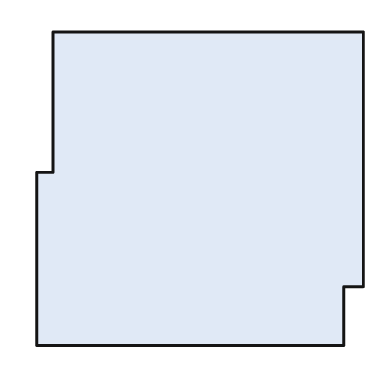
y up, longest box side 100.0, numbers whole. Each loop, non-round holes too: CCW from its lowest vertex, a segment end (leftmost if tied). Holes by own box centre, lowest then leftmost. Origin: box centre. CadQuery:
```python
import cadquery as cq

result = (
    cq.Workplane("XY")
    .moveTo(-50.0, -48.0)
    .lineTo(44.0, -48.0)
    .lineTo(44.0, -30.0)
    .lineTo(50.0, -30.0)
    .lineTo(50.0, 48.0)
    .lineTo(-45.0, 48.0)
    .lineTo(-45.0, 5.0)
    .lineTo(-50.0, 5.0)
    .close()
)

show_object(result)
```